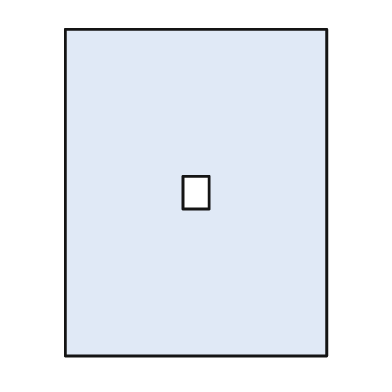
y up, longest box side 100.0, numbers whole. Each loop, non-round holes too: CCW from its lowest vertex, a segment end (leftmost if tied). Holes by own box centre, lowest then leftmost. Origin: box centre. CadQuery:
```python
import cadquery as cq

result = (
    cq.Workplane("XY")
    .moveTo(-40.0, -50.0)
    .lineTo(40.0, -50.0)
    .lineTo(40.0, 50.0)
    .lineTo(-40.0, 50.0)
    .close()
    .moveTo(-4.0, -5.0)
    .lineTo(4.0, -5.0)
    .lineTo(4.0, 5.0)
    .lineTo(-4.0, 5.0)
    .close()
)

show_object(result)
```